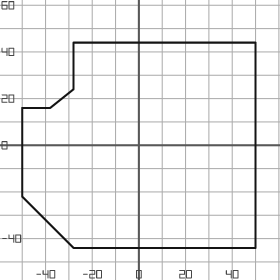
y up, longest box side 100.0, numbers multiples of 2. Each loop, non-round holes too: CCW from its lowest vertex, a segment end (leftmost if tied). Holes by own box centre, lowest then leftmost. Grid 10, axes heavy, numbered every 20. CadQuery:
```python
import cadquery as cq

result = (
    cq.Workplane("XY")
    .moveTo(-28.0, -44.0)
    .lineTo(50.0, -44.0)
    .lineTo(50.0, 44.0)
    .lineTo(-28.0, 44.0)
    .lineTo(-28.0, 24.0)
    .lineTo(-38.0, 16.0)
    .lineTo(-50.0, 16.0)
    .lineTo(-50.0, -22.0)
    .close()
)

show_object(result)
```